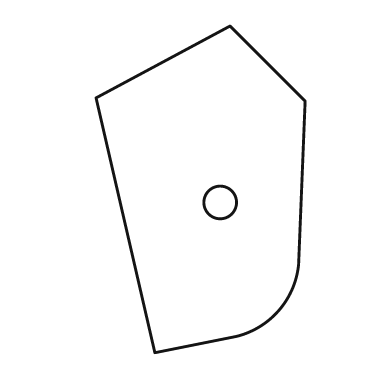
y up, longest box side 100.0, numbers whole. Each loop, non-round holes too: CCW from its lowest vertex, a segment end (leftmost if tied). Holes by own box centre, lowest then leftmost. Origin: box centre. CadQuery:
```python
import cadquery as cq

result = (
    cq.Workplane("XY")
    .moveTo(-14.0, -50.0)
    .lineTo(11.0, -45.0)
    .threePointArc((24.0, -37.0), (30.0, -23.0))
    .lineTo(32.0, 27.0)
    .lineTo(9.0, 50.0)
    .lineTo(-32.0, 28.0)
    .close()
    .moveTo(6.0, -4.0)
    .circle(5.0)
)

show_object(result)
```